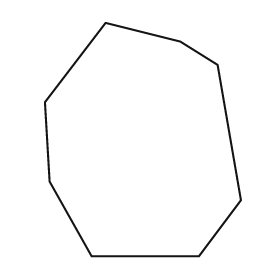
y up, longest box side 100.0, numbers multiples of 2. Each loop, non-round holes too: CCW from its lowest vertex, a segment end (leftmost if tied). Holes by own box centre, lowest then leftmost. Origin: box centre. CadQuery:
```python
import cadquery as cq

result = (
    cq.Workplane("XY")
    .moveTo(-22.0, -50.0)
    .lineTo(24.0, -50.0)
    .lineTo(42.0, -26.0)
    .lineTo(32.0, 32.0)
    .lineTo(16.0, 42.0)
    .lineTo(-16.0, 50.0)
    .lineTo(-42.0, 16.0)
    .lineTo(-40.0, -18.0)
    .close()
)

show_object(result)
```